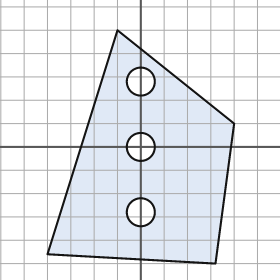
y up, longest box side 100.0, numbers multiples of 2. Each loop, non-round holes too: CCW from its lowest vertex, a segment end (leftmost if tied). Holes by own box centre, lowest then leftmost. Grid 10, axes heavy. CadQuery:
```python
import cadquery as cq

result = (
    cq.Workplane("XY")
    .moveTo(32.0, -50.0)
    .lineTo(40.0, 10.0)
    .lineTo(-10.0, 50.0)
    .lineTo(-40.0, -46.0)
    .close()
    .moveTo(0.0, -28.0)
    .circle(6.0)
    .moveTo(0.0, 0.0)
    .circle(6.0)
    .moveTo(0.0, 28.0)
    .circle(6.0)
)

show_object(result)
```